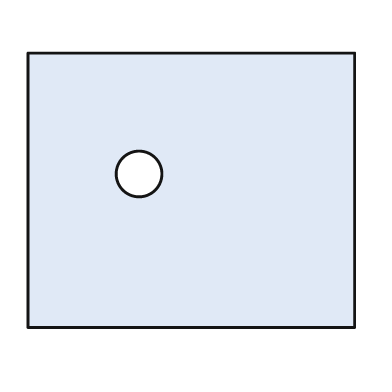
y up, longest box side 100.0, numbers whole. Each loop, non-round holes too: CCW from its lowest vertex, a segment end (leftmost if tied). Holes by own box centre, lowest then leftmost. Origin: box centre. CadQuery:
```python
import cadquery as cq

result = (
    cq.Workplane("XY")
    .moveTo(-50.0, -42.0)
    .lineTo(50.0, -42.0)
    .lineTo(50.0, 42.0)
    .lineTo(-50.0, 42.0)
    .close()
    .moveTo(-16.0, 5.0)
    .circle(7.0)
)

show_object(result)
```